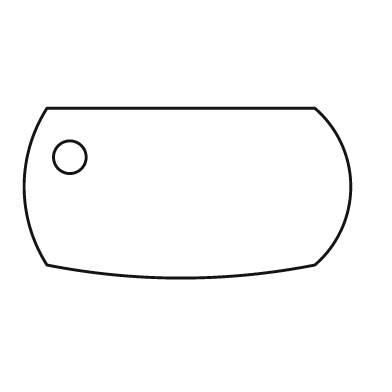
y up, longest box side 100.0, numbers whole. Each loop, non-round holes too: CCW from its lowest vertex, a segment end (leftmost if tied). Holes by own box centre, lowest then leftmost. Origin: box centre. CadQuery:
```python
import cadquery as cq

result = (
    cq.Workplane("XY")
    .moveTo(-43.0, -22.0)
    .threePointArc((-2.0, -26.0), (39.0, -22.0))
    .threePointArc((50.0, 2.0), (39.0, 26.0))
    .lineTo(-43.0, 26.0)
    .threePointArc((-50.0, 2.0), (-43.0, -22.0))
    .close()
    .moveTo(-36.0, 11.0)
    .circle(5.0)
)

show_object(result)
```